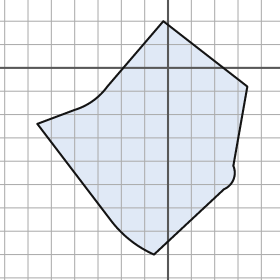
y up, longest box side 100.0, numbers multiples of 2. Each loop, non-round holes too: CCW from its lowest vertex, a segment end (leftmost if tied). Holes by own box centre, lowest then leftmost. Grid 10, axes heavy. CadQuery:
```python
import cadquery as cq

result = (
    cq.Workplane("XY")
    .moveTo(-6.0, -80.0)
    .lineTo(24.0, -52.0)
    .threePointArc((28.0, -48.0), (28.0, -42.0))
    .lineTo(34.0, -8.0)
    .lineTo(-2.0, 20.0)
    .lineTo(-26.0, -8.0)
    .threePointArc((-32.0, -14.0), (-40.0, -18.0))
    .lineTo(-56.0, -24.0)
    .lineTo(-24.0, -66.0)
    .threePointArc((-16.0, -74.0), (-6.0, -80.0))
    .close()
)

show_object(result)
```